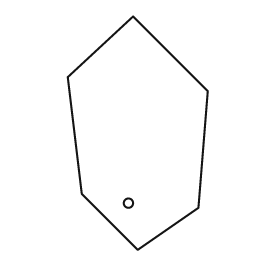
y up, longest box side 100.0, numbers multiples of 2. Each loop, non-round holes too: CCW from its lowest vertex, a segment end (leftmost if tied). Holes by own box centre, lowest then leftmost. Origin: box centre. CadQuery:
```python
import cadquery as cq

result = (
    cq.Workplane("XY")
    .moveTo(0.0, -50.0)
    .lineTo(26.0, -32.0)
    .lineTo(30.0, 18.0)
    .lineTo(-2.0, 50.0)
    .lineTo(-30.0, 24.0)
    .lineTo(-24.0, -26.0)
    .close()
    .moveTo(-4.0, -30.0)
    .circle(2.0)
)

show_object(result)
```